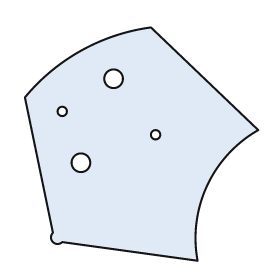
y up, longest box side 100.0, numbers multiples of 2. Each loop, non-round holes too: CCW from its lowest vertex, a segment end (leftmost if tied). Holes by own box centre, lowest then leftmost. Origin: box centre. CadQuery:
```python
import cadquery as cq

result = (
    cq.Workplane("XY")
    .moveTo(24.0, -50.0)
    .threePointArc((28.0, -18.0), (50.0, 6.0))
    .lineTo(4.0, 50.0)
    .threePointArc((-26.0, 40.0), (-50.0, 20.0))
    .lineTo(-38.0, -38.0)
    .threePointArc((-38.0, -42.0), (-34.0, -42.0))
    .close()
    .moveTo(-26.0, -8.0)
    .circle(4.0)
    .moveTo(6.0, 4.0)
    .circle(2.0)
    .moveTo(-34.0, 14.0)
    .circle(2.0)
    .moveTo(-12.0, 28.0)
    .circle(4.0)
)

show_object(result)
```